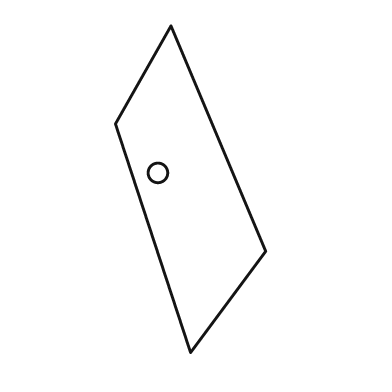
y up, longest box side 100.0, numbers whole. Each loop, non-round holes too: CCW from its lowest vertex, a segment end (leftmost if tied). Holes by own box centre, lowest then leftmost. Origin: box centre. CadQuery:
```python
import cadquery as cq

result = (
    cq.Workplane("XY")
    .moveTo(0.0, -50.0)
    .lineTo(23.0, -19.0)
    .lineTo(-6.0, 50.0)
    .lineTo(-23.0, 20.0)
    .close()
    .moveTo(-10.0, 5.0)
    .circle(3.0)
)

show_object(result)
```